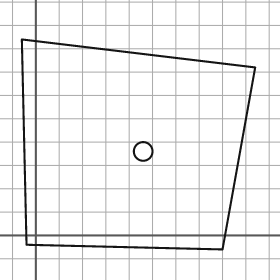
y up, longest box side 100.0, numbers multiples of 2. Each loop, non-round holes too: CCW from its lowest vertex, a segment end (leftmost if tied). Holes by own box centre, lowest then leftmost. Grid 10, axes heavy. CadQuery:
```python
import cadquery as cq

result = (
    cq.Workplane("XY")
    .moveTo(80.0, -6.0)
    .lineTo(94.0, 72.0)
    .lineTo(-6.0, 84.0)
    .lineTo(-4.0, -4.0)
    .close()
    .moveTo(46.0, 36.0)
    .circle(4.0)
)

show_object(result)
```